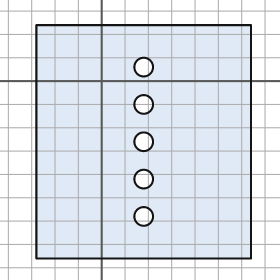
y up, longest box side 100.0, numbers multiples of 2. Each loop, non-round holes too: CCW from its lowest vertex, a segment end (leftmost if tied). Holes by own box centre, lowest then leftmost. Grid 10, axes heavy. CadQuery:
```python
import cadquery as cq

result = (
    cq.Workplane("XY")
    .moveTo(-28.0, -76.0)
    .lineTo(64.0, -76.0)
    .lineTo(64.0, 24.0)
    .lineTo(-28.0, 24.0)
    .close()
    .moveTo(18.0, -58.0)
    .circle(4.0)
    .moveTo(18.0, -42.0)
    .circle(4.0)
    .moveTo(18.0, -26.0)
    .circle(4.0)
    .moveTo(18.0, -10.0)
    .circle(4.0)
    .moveTo(18.0, 6.0)
    .circle(4.0)
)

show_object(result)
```